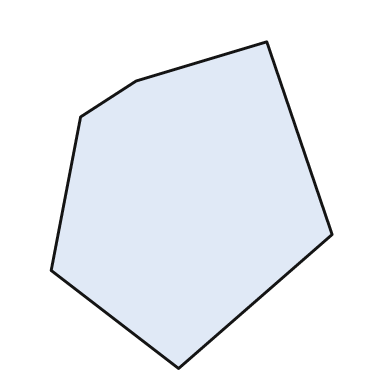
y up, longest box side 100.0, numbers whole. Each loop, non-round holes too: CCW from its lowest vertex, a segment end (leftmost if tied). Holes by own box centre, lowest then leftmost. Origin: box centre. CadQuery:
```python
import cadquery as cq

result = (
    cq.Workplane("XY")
    .moveTo(-4.0, -50.0)
    .lineTo(43.0, -9.0)
    .lineTo(23.0, 50.0)
    .lineTo(-17.0, 38.0)
    .lineTo(-34.0, 27.0)
    .lineTo(-43.0, -20.0)
    .close()
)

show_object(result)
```